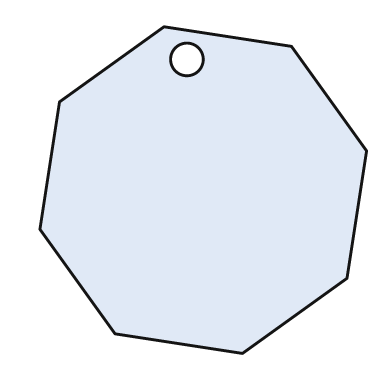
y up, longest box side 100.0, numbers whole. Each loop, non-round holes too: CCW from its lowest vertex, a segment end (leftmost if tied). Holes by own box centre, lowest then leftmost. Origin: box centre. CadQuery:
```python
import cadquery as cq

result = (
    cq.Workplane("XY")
    .moveTo(12.0, -50.0)
    .lineTo(44.0, -27.0)
    .lineTo(50.0, 12.0)
    .lineTo(27.0, 44.0)
    .lineTo(-12.0, 50.0)
    .lineTo(-44.0, 27.0)
    .lineTo(-50.0, -12.0)
    .lineTo(-27.0, -44.0)
    .close()
    .moveTo(-5.0, 40.0)
    .circle(5.0)
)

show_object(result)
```